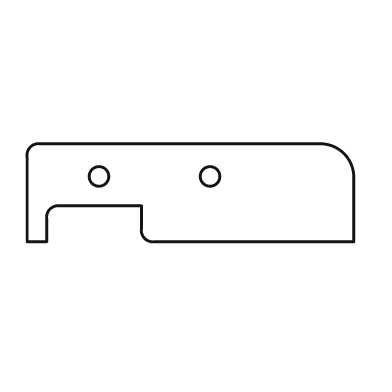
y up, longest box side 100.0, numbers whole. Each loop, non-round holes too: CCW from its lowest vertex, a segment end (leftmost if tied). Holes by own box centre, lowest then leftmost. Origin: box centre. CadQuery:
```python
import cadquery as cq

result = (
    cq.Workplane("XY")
    .moveTo(-50.0, -15.0)
    .lineTo(-44.0, -15.0)
    .lineTo(-44.0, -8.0)
    .threePointArc((-43.0, -5.0), (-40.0, -4.0))
    .lineTo(-15.0, -4.0)
    .lineTo(-15.0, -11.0)
    .threePointArc((-14.0, -14.0), (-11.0, -15.0))
    .lineTo(50.0, -15.0)
    .lineTo(50.0, 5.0)
    .threePointArc((47.0, 12.0), (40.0, 15.0))
    .lineTo(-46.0, 15.0)
    .threePointArc((-49.0, 14.0), (-50.0, 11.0))
    .close()
    .moveTo(-28.0, 5.0)
    .circle(3.0)
    .moveTo(6.0, 5.0)
    .circle(3.0)
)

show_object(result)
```